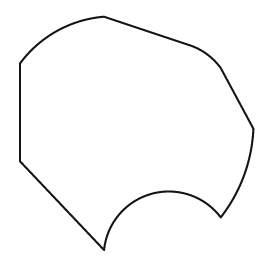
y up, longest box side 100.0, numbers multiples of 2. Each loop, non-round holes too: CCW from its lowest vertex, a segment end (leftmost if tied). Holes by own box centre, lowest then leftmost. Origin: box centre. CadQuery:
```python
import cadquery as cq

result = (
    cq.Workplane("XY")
    .moveTo(-14.0, -50.0)
    .threePointArc((6.0, -26.0), (36.0, -36.0))
    .threePointArc((46.0, -18.0), (50.0, 2.0))
    .lineTo(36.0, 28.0)
    .threePointArc((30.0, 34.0), (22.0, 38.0))
    .lineTo(-14.0, 50.0)
    .threePointArc((-34.0, 44.0), (-50.0, 30.0))
    .lineTo(-50.0, -12.0)
    .close()
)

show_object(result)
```